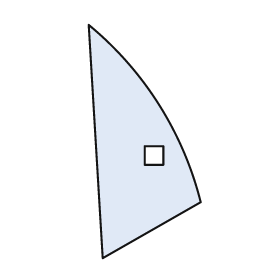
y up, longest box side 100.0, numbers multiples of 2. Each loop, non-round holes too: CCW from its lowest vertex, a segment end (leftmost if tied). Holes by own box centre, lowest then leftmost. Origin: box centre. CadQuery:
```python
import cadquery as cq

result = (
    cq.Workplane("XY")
    .moveTo(-18.0, -50.0)
    .lineTo(24.0, -26.0)
    .threePointArc((6.0, 16.0), (-24.0, 50.0))
    .close()
    .moveTo(0.0, -10.0)
    .lineTo(8.0, -10.0)
    .lineTo(8.0, -2.0)
    .lineTo(0.0, -2.0)
    .close()
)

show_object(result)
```